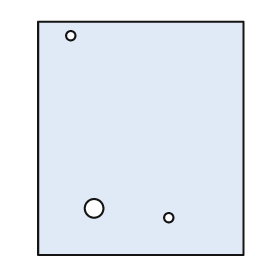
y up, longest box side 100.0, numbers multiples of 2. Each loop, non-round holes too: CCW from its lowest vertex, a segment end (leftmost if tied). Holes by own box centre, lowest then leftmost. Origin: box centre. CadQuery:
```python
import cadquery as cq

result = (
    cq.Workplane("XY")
    .moveTo(-44.0, -50.0)
    .lineTo(44.0, -50.0)
    .lineTo(44.0, 50.0)
    .lineTo(-44.0, 50.0)
    .close()
    .moveTo(12.0, -34.0)
    .circle(2.0)
    .moveTo(-20.0, -30.0)
    .circle(4.0)
    .moveTo(-30.0, 44.0)
    .circle(2.0)
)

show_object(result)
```